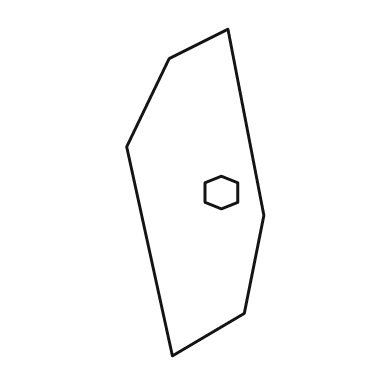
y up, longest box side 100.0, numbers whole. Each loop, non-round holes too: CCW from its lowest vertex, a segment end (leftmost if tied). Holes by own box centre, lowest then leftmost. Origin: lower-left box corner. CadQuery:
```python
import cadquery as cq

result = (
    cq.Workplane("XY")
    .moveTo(14.0, 0.0)
    .lineTo(36.0, 13.0)
    .lineTo(42.0, 43.0)
    .lineTo(31.0, 100.0)
    .lineTo(13.0, 91.0)
    .lineTo(0.0, 64.0)
    .close()
    .moveTo(29.0, 45.0)
    .lineTo(34.0, 47.0)
    .lineTo(34.0, 53.0)
    .lineTo(29.0, 55.0)
    .lineTo(24.0, 53.0)
    .lineTo(24.0, 47.0)
    .close()
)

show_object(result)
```